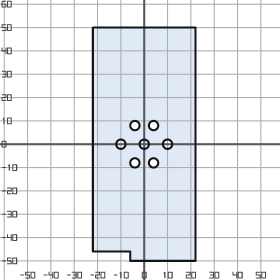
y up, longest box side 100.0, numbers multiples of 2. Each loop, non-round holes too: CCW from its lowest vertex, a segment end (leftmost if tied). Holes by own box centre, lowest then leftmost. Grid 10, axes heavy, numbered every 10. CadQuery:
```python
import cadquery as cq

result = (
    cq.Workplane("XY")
    .moveTo(-6.0, -50.0)
    .lineTo(22.0, -50.0)
    .lineTo(22.0, 50.0)
    .lineTo(-22.0, 50.0)
    .lineTo(-22.0, -46.0)
    .lineTo(-6.0, -46.0)
    .close()
    .moveTo(-4.0, -8.0)
    .circle(2.0)
    .moveTo(4.0, -8.0)
    .circle(2.0)
    .moveTo(-10.0, 0.0)
    .circle(2.0)
    .moveTo(0.0, 0.0)
    .circle(2.0)
    .moveTo(10.0, 0.0)
    .circle(2.0)
    .moveTo(-4.0, 8.0)
    .circle(2.0)
    .moveTo(4.0, 8.0)
    .circle(2.0)
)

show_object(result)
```